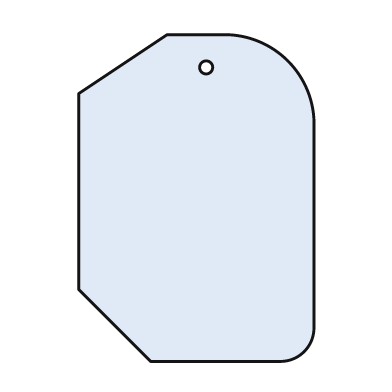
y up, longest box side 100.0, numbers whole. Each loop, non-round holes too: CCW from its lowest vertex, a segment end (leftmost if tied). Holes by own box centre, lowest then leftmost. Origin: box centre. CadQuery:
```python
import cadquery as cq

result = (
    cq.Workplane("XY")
    .moveTo(-14.0, -50.0)
    .lineTo(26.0, -50.0)
    .threePointArc((33.0, -47.0), (36.0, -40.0))
    .lineTo(36.0, 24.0)
    .threePointArc((28.0, 42.0), (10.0, 50.0))
    .lineTo(-9.0, 50.0)
    .lineTo(-36.0, 32.0)
    .lineTo(-36.0, -28.0)
    .close()
    .moveTo(3.0, 40.0)
    .circle(2.0)
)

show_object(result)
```